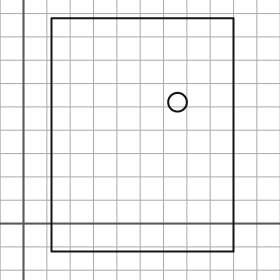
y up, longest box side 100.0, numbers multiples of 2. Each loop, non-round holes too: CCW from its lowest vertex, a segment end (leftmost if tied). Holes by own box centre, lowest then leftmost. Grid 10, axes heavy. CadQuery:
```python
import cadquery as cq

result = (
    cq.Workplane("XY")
    .moveTo(12.0, -12.0)
    .lineTo(90.0, -12.0)
    .lineTo(90.0, 88.0)
    .lineTo(12.0, 88.0)
    .close()
    .moveTo(66.0, 52.0)
    .circle(4.0)
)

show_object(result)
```